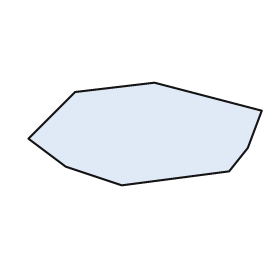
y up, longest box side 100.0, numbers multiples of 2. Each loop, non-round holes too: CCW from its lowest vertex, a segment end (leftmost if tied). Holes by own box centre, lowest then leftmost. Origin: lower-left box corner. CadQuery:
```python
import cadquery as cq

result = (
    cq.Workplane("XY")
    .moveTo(40.0, 0.0)
    .lineTo(86.0, 6.0)
    .lineTo(94.0, 16.0)
    .lineTo(100.0, 32.0)
    .lineTo(54.0, 44.0)
    .lineTo(20.0, 40.0)
    .lineTo(0.0, 20.0)
    .lineTo(16.0, 8.0)
    .close()
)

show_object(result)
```